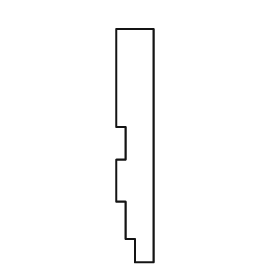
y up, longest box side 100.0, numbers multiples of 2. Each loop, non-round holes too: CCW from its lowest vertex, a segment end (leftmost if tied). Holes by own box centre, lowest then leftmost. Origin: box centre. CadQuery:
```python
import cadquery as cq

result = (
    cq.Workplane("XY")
    .moveTo(0.0, -50.0)
    .lineTo(8.0, -50.0)
    .lineTo(8.0, 50.0)
    .lineTo(-8.0, 50.0)
    .lineTo(-8.0, 8.0)
    .lineTo(-4.0, 8.0)
    .lineTo(-4.0, -6.0)
    .lineTo(-8.0, -6.0)
    .lineTo(-8.0, -24.0)
    .lineTo(-4.0, -24.0)
    .lineTo(-4.0, -40.0)
    .lineTo(0.0, -40.0)
    .close()
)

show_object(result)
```